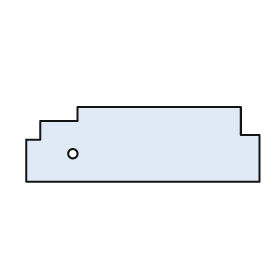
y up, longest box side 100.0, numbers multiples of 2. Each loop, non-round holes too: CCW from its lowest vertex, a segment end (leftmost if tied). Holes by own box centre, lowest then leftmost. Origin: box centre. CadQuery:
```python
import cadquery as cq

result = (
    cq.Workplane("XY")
    .moveTo(-50.0, -16.0)
    .lineTo(50.0, -16.0)
    .lineTo(50.0, 4.0)
    .lineTo(42.0, 4.0)
    .lineTo(42.0, 16.0)
    .lineTo(-28.0, 16.0)
    .lineTo(-28.0, 10.0)
    .lineTo(-44.0, 10.0)
    .lineTo(-44.0, 2.0)
    .lineTo(-50.0, 2.0)
    .close()
    .moveTo(-30.0, -4.0)
    .circle(2.0)
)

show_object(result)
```